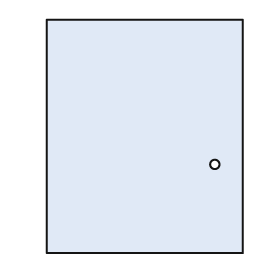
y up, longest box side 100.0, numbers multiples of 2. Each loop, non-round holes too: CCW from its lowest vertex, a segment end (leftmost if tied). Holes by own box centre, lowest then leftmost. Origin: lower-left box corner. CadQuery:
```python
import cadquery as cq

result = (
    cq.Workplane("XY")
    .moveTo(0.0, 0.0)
    .lineTo(84.0, 0.0)
    .lineTo(84.0, 100.0)
    .lineTo(0.0, 100.0)
    .close()
    .moveTo(72.0, 38.0)
    .circle(2.0)
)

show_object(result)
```